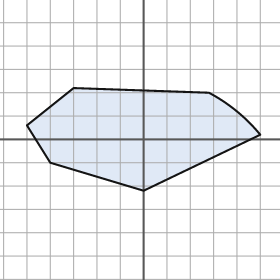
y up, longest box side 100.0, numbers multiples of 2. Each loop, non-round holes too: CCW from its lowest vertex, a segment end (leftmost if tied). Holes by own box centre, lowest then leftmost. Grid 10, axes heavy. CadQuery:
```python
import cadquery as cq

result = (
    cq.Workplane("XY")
    .moveTo(0.0, -22.0)
    .lineTo(50.0, 2.0)
    .threePointArc((40.0, 12.0), (28.0, 20.0))
    .lineTo(-30.0, 22.0)
    .lineTo(-50.0, 6.0)
    .lineTo(-40.0, -10.0)
    .close()
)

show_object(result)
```